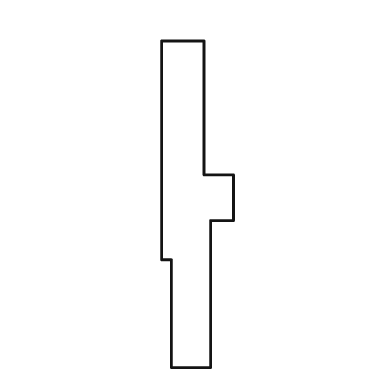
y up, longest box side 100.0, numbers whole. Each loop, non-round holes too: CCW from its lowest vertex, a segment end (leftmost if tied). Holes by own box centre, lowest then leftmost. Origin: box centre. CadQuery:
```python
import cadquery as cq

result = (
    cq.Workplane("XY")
    .moveTo(-8.0, -50.0)
    .lineTo(4.0, -50.0)
    .lineTo(4.0, -5.0)
    .lineTo(11.0, -5.0)
    .lineTo(11.0, 9.0)
    .lineTo(2.0, 9.0)
    .lineTo(2.0, 50.0)
    .lineTo(-11.0, 50.0)
    .lineTo(-11.0, -17.0)
    .lineTo(-8.0, -17.0)
    .close()
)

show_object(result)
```